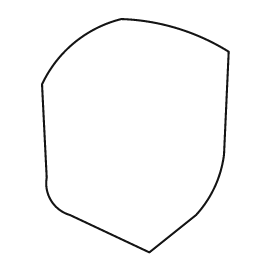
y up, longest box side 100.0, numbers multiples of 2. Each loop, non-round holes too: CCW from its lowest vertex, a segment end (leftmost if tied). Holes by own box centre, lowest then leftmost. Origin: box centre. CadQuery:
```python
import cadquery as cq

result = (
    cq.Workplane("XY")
    .moveTo(6.0, -50.0)
    .lineTo(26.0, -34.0)
    .threePointArc((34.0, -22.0), (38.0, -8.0))
    .lineTo(40.0, 36.0)
    .threePointArc((18.0, 46.0), (-6.0, 50.0))
    .threePointArc((-26.0, 40.0), (-40.0, 22.0))
    .lineTo(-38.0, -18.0)
    .threePointArc((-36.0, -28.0), (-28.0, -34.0))
    .close()
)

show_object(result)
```